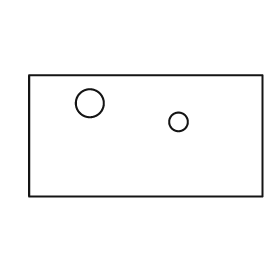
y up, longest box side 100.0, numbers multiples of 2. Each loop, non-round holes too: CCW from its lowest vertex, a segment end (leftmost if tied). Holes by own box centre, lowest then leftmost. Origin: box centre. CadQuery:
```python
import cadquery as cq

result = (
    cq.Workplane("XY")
    .moveTo(-50.0, -26.0)
    .lineTo(50.0, -26.0)
    .lineTo(50.0, 26.0)
    .lineTo(-50.0, 26.0)
    .close()
    .moveTo(14.0, 6.0)
    .circle(4.0)
    .moveTo(-24.0, 14.0)
    .circle(6.0)
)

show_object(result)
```